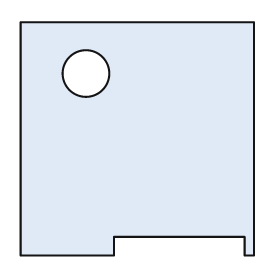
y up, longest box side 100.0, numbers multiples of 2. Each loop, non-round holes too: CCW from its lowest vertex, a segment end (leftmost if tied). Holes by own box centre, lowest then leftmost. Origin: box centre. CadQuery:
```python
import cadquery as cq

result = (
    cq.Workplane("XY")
    .moveTo(-50.0, -50.0)
    .lineTo(-10.0, -50.0)
    .lineTo(-10.0, -42.0)
    .lineTo(46.0, -42.0)
    .lineTo(46.0, -50.0)
    .lineTo(50.0, -50.0)
    .lineTo(50.0, 50.0)
    .lineTo(-50.0, 50.0)
    .close()
    .moveTo(-22.0, 28.0)
    .circle(10.0)
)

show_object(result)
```